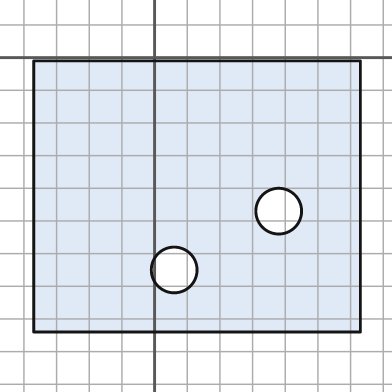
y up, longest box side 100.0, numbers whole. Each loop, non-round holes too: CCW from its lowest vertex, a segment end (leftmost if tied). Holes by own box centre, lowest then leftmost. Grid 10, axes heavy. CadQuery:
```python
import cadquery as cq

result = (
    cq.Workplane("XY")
    .moveTo(-37.0, -84.0)
    .lineTo(63.0, -84.0)
    .lineTo(63.0, -1.0)
    .lineTo(-37.0, -1.0)
    .close()
    .moveTo(6.0, -65.0)
    .circle(7.0)
    .moveTo(38.0, -47.0)
    .circle(7.0)
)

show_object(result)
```